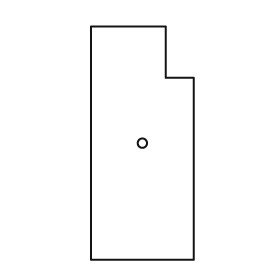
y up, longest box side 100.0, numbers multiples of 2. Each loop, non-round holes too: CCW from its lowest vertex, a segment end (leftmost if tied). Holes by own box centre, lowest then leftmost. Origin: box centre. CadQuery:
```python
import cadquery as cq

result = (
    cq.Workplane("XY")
    .moveTo(-22.0, -50.0)
    .lineTo(22.0, -50.0)
    .lineTo(22.0, 28.0)
    .lineTo(10.0, 28.0)
    .lineTo(10.0, 50.0)
    .lineTo(-22.0, 50.0)
    .close()
    .moveTo(0.0, 0.0)
    .circle(2.0)
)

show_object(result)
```